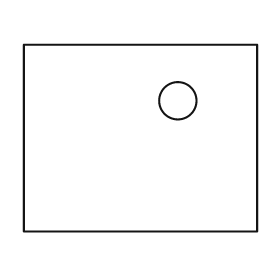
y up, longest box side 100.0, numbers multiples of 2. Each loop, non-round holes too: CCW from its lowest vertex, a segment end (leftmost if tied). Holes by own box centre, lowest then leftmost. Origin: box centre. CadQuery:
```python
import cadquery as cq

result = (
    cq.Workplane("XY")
    .moveTo(-50.0, -40.0)
    .lineTo(50.0, -40.0)
    .lineTo(50.0, 40.0)
    .lineTo(-50.0, 40.0)
    .close()
    .moveTo(16.0, 16.0)
    .circle(8.0)
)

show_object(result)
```